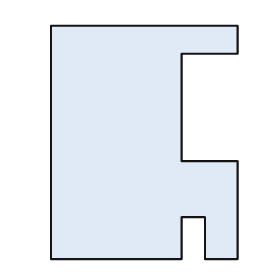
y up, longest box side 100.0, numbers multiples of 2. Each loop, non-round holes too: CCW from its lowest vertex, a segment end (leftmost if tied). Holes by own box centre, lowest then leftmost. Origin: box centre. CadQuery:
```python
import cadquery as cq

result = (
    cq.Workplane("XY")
    .moveTo(-40.0, -50.0)
    .lineTo(16.0, -50.0)
    .lineTo(16.0, -32.0)
    .lineTo(26.0, -32.0)
    .lineTo(26.0, -50.0)
    .lineTo(40.0, -50.0)
    .lineTo(40.0, -8.0)
    .lineTo(16.0, -8.0)
    .lineTo(16.0, 38.0)
    .lineTo(40.0, 38.0)
    .lineTo(40.0, 50.0)
    .lineTo(-40.0, 50.0)
    .close()
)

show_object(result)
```